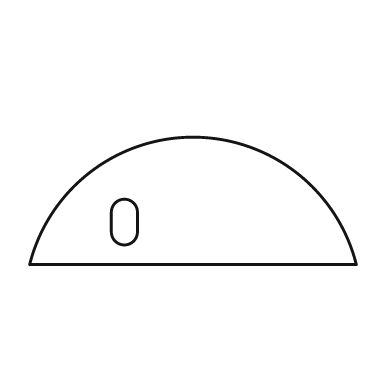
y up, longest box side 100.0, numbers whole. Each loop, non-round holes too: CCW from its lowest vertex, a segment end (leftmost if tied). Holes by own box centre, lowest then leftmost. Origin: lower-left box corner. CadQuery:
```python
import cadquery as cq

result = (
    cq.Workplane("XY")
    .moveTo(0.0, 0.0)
    .lineTo(100.0, 0.0)
    .threePointArc((50.0, 39.0), (0.0, 0.0))
    .close()
    .moveTo(25.0, 10.0)
    .threePointArc((29.0, 6.0), (33.0, 10.0))
    .lineTo(33.0, 16.0)
    .threePointArc((29.0, 20.0), (25.0, 16.0))
    .close()
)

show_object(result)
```